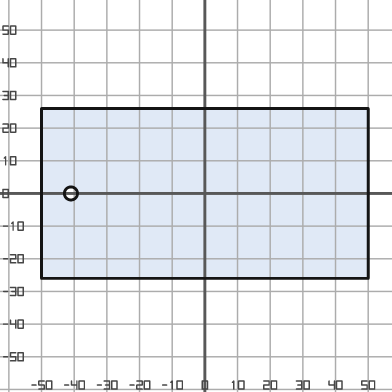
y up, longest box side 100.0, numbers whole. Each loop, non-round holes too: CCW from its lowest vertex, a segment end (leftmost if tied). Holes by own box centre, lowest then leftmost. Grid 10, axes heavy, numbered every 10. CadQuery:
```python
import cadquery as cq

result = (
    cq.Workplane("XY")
    .moveTo(-50.0, -26.0)
    .lineTo(50.0, -26.0)
    .lineTo(50.0, 26.0)
    .lineTo(-50.0, 26.0)
    .close()
    .moveTo(-41.0, 0.0)
    .circle(2.0)
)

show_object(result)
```